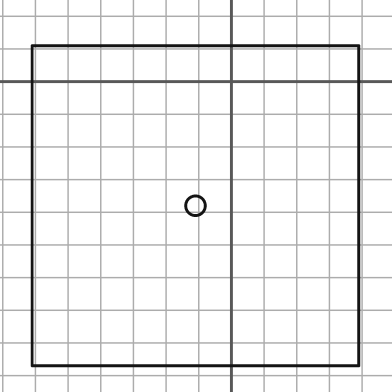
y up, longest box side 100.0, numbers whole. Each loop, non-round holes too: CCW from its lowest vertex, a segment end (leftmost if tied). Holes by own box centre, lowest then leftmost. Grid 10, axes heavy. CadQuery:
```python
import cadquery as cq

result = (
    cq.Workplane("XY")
    .moveTo(-61.0, -87.0)
    .lineTo(39.0, -87.0)
    .lineTo(39.0, 11.0)
    .lineTo(-61.0, 11.0)
    .close()
    .moveTo(-11.0, -38.0)
    .circle(3.0)
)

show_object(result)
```